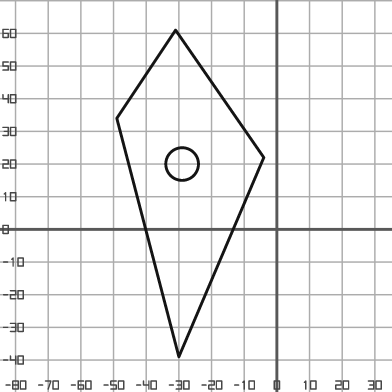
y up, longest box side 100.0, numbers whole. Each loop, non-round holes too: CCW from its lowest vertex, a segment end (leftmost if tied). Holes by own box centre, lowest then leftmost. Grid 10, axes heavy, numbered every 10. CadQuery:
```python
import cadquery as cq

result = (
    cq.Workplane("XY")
    .moveTo(-30.0, -39.0)
    .lineTo(-4.0, 22.0)
    .lineTo(-31.0, 61.0)
    .lineTo(-49.0, 34.0)
    .close()
    .moveTo(-29.0, 20.0)
    .circle(5.0)
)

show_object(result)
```